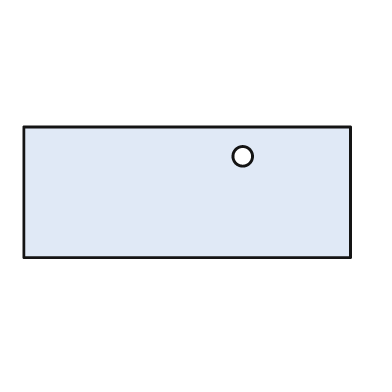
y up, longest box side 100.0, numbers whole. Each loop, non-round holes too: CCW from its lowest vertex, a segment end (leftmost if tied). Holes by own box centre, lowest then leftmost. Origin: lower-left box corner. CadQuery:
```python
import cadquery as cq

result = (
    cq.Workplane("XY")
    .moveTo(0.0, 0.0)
    .lineTo(100.0, 0.0)
    .lineTo(100.0, 40.0)
    .lineTo(0.0, 40.0)
    .close()
    .moveTo(67.0, 31.0)
    .circle(3.0)
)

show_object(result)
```